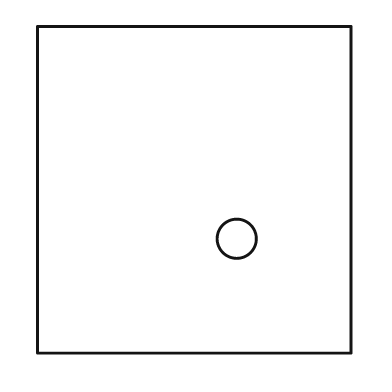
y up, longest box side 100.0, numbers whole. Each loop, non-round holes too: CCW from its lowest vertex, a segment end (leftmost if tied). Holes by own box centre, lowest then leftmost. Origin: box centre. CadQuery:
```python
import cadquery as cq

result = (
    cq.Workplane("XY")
    .moveTo(-48.0, -50.0)
    .lineTo(48.0, -50.0)
    .lineTo(48.0, 50.0)
    .lineTo(-48.0, 50.0)
    .close()
    .moveTo(13.0, -15.0)
    .circle(6.0)
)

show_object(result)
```